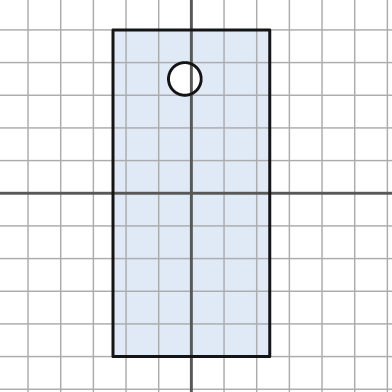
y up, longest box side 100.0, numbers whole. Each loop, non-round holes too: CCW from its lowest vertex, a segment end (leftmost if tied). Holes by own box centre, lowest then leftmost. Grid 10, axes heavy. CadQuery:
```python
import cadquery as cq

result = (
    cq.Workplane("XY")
    .moveTo(-24.0, -50.0)
    .lineTo(24.0, -50.0)
    .lineTo(24.0, 50.0)
    .lineTo(-24.0, 50.0)
    .close()
    .moveTo(-2.0, 35.0)
    .circle(5.0)
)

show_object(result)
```